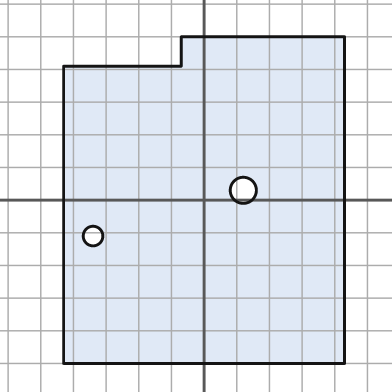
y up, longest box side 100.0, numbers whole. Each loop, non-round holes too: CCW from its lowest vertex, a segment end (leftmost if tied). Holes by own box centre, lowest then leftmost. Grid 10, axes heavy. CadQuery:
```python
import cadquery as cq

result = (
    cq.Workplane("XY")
    .moveTo(-43.0, -50.0)
    .lineTo(43.0, -50.0)
    .lineTo(43.0, 50.0)
    .lineTo(-7.0, 50.0)
    .lineTo(-7.0, 41.0)
    .lineTo(-43.0, 41.0)
    .close()
    .moveTo(-34.0, -11.0)
    .circle(3.0)
    .moveTo(12.0, 3.0)
    .circle(4.0)
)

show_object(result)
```